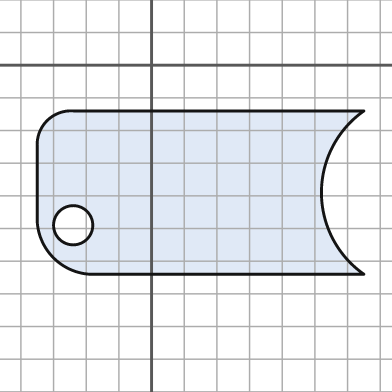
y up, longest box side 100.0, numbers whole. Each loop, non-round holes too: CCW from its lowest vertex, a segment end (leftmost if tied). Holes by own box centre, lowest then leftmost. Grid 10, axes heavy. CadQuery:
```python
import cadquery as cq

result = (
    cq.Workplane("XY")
    .moveTo(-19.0, -64.0)
    .lineTo(65.0, -64.0)
    .threePointArc((52.0, -39.0), (65.0, -14.0))
    .lineTo(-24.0, -14.0)
    .threePointArc((-32.0, -17.0), (-35.0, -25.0))
    .lineTo(-35.0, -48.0)
    .threePointArc((-30.0, -59.0), (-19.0, -64.0))
    .close()
    .moveTo(-24.0, -49.0)
    .circle(6.0)
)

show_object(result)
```